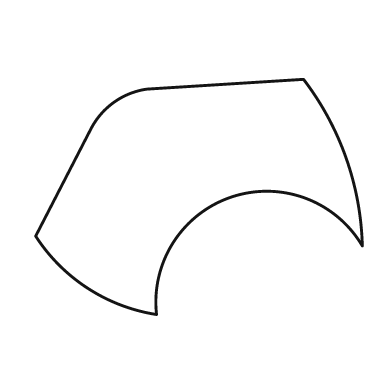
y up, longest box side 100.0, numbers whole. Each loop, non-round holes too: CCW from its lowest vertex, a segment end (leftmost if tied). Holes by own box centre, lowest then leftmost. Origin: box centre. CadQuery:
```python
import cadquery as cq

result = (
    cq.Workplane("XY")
    .moveTo(-13.0, -36.0)
    .threePointArc((10.0, 0.0), (50.0, -15.0))
    .threePointArc((45.0, 12.0), (32.0, 36.0))
    .lineTo(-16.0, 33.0)
    .threePointArc((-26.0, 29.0), (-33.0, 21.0))
    .lineTo(-50.0, -12.0)
    .threePointArc((-34.0, -28.0), (-13.0, -36.0))
    .close()
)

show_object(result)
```